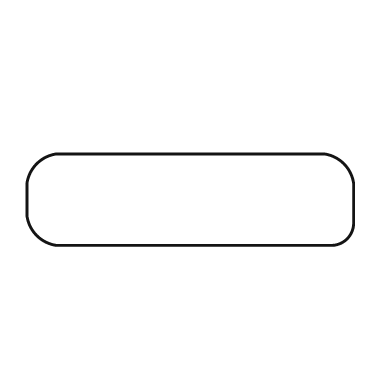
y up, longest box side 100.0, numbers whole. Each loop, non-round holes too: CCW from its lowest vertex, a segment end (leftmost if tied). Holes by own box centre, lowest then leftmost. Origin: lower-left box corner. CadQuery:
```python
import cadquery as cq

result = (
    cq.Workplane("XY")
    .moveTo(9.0, 0.0)
    .lineTo(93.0, 0.0)
    .threePointArc((98.0, 2.0), (100.0, 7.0))
    .lineTo(100.0, 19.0)
    .threePointArc((97.0, 25.0), (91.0, 28.0))
    .lineTo(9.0, 28.0)
    .threePointArc((3.0, 25.0), (0.0, 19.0))
    .lineTo(0.0, 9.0)
    .threePointArc((3.0, 3.0), (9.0, 0.0))
    .close()
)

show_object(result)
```